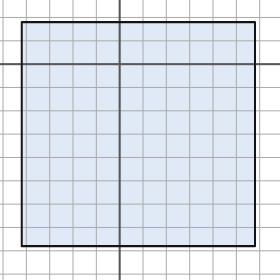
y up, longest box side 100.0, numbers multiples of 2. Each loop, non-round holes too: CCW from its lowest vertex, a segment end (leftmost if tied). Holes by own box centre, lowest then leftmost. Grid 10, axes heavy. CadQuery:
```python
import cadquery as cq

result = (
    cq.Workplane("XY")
    .moveTo(-42.0, -78.0)
    .lineTo(58.0, -78.0)
    .lineTo(58.0, 18.0)
    .lineTo(-42.0, 18.0)
    .close()
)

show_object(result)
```